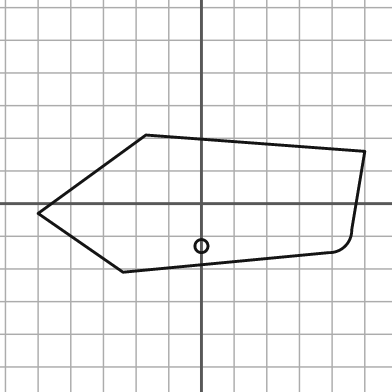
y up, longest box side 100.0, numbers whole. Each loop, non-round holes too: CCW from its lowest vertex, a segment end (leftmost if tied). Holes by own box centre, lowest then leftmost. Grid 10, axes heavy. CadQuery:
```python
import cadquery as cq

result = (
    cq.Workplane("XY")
    .moveTo(-24.0, -21.0)
    .lineTo(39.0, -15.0)
    .threePointArc((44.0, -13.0), (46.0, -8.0))
    .lineTo(50.0, 16.0)
    .lineTo(-17.0, 21.0)
    .lineTo(-50.0, -3.0)
    .close()
    .moveTo(0.0, -13.0)
    .circle(2.0)
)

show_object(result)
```